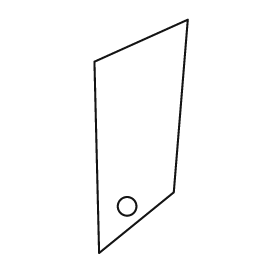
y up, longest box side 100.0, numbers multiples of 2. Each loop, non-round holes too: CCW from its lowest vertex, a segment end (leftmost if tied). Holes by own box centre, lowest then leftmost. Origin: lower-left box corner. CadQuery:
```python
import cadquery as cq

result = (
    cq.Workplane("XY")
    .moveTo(2.0, 0.0)
    .lineTo(34.0, 26.0)
    .lineTo(40.0, 100.0)
    .lineTo(0.0, 82.0)
    .close()
    .moveTo(14.0, 20.0)
    .circle(4.0)
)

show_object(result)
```